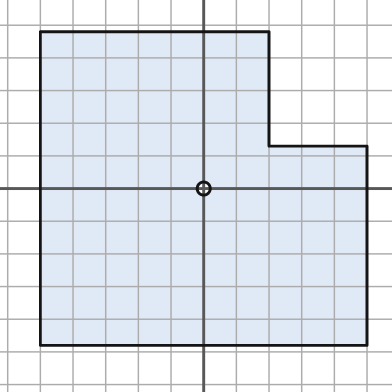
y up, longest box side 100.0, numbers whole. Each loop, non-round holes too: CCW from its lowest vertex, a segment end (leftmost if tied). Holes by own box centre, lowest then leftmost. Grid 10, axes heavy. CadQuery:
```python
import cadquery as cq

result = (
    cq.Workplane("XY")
    .moveTo(-50.0, -48.0)
    .lineTo(50.0, -48.0)
    .lineTo(50.0, 13.0)
    .lineTo(20.0, 13.0)
    .lineTo(20.0, 48.0)
    .lineTo(-50.0, 48.0)
    .close()
    .moveTo(0.0, 0.0)
    .circle(2.0)
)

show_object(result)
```